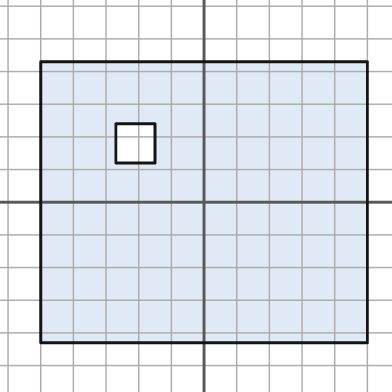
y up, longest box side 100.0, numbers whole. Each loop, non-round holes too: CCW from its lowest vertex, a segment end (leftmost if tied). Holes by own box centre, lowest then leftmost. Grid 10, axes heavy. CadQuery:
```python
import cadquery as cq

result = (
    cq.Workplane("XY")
    .moveTo(-50.0, -43.0)
    .lineTo(50.0, -43.0)
    .lineTo(50.0, 43.0)
    .lineTo(-50.0, 43.0)
    .close()
    .moveTo(-27.0, 12.0)
    .lineTo(-15.0, 12.0)
    .lineTo(-15.0, 24.0)
    .lineTo(-27.0, 24.0)
    .close()
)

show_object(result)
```